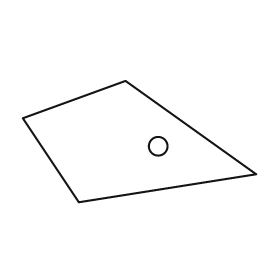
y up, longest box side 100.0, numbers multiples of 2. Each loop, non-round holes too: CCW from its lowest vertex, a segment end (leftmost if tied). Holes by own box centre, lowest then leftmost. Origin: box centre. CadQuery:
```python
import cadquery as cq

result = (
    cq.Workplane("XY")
    .moveTo(-26.0, -26.0)
    .lineTo(50.0, -14.0)
    .lineTo(-6.0, 26.0)
    .lineTo(-50.0, 10.0)
    .close()
    .moveTo(8.0, -2.0)
    .circle(4.0)
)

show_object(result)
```